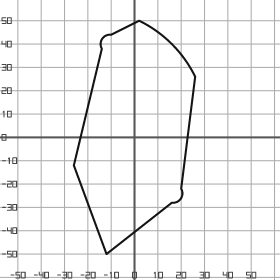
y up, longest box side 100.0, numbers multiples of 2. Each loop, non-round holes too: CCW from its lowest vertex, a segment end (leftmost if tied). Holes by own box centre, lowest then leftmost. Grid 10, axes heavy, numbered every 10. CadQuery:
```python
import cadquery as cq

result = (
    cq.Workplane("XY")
    .moveTo(-12.0, -50.0)
    .lineTo(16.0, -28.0)
    .threePointArc((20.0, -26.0), (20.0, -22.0))
    .lineTo(26.0, 26.0)
    .threePointArc((16.0, 40.0), (2.0, 50.0))
    .lineTo(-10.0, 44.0)
    .threePointArc((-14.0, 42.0), (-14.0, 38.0))
    .lineTo(-26.0, -12.0)
    .close()
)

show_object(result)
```